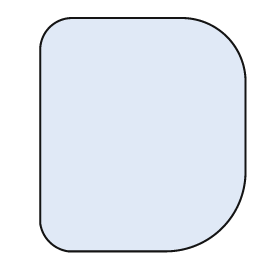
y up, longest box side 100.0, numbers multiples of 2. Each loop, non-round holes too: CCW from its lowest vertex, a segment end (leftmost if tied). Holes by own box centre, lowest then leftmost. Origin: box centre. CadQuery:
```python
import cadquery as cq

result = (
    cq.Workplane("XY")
    .moveTo(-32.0, -50.0)
    .lineTo(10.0, -50.0)
    .threePointArc((34.0, -40.0), (44.0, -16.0))
    .lineTo(44.0, 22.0)
    .threePointArc((36.0, 42.0), (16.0, 50.0))
    .lineTo(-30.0, 50.0)
    .threePointArc((-40.0, 46.0), (-44.0, 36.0))
    .lineTo(-44.0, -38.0)
    .threePointArc((-40.0, -46.0), (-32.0, -50.0))
    .close()
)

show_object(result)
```